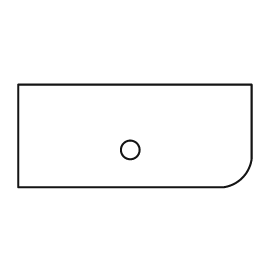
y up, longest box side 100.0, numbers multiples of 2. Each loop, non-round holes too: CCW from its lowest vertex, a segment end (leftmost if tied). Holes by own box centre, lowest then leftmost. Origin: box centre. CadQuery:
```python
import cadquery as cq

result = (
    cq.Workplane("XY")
    .moveTo(-50.0, -22.0)
    .lineTo(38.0, -22.0)
    .threePointArc((46.0, -18.0), (50.0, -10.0))
    .lineTo(50.0, 22.0)
    .lineTo(-50.0, 22.0)
    .close()
    .moveTo(-2.0, -6.0)
    .circle(4.0)
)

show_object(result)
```